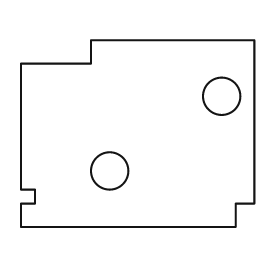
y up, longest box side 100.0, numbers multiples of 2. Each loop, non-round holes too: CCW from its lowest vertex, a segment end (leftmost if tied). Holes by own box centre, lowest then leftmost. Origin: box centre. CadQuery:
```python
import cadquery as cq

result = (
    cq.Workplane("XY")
    .moveTo(-50.0, -40.0)
    .lineTo(42.0, -40.0)
    .lineTo(42.0, -30.0)
    .lineTo(50.0, -30.0)
    .lineTo(50.0, 40.0)
    .lineTo(-20.0, 40.0)
    .lineTo(-20.0, 30.0)
    .lineTo(-50.0, 30.0)
    .lineTo(-50.0, -24.0)
    .lineTo(-44.0, -24.0)
    .lineTo(-44.0, -30.0)
    .lineTo(-50.0, -30.0)
    .close()
    .moveTo(-12.0, -16.0)
    .circle(8.0)
    .moveTo(36.0, 16.0)
    .circle(8.0)
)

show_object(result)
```